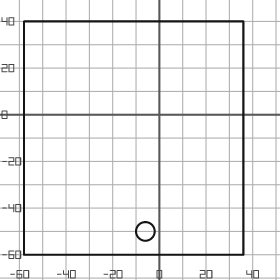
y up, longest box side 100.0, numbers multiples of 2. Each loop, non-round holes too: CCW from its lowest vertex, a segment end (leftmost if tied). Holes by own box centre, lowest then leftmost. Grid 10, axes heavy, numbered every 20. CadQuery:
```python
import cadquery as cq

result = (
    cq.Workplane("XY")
    .moveTo(-58.0, -60.0)
    .lineTo(36.0, -60.0)
    .lineTo(36.0, 40.0)
    .lineTo(-58.0, 40.0)
    .close()
    .moveTo(-6.0, -50.0)
    .circle(4.0)
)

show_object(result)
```